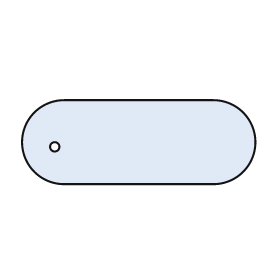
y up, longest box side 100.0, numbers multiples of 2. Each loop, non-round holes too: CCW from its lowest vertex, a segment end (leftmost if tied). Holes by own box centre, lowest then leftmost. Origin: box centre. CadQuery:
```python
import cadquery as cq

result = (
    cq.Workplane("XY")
    .moveTo(-32.0, -18.0)
    .lineTo(32.0, -18.0)
    .threePointArc((50.0, 0.0), (32.0, 18.0))
    .lineTo(-32.0, 18.0)
    .threePointArc((-50.0, 0.0), (-32.0, -18.0))
    .close()
    .moveTo(-36.0, -2.0)
    .circle(2.0)
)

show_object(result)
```